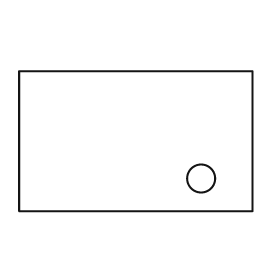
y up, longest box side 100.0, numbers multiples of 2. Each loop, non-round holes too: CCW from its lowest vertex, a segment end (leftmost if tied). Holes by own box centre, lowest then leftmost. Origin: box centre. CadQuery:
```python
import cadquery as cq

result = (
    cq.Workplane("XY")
    .moveTo(-50.0, -30.0)
    .lineTo(50.0, -30.0)
    .lineTo(50.0, 30.0)
    .lineTo(-50.0, 30.0)
    .close()
    .moveTo(28.0, -16.0)
    .circle(6.0)
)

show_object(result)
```